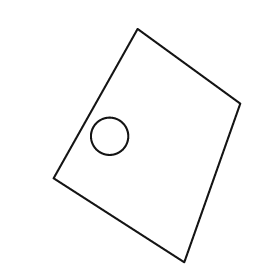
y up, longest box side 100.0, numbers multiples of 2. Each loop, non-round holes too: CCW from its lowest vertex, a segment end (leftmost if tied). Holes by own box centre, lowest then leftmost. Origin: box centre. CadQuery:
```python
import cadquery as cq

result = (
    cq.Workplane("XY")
    .moveTo(16.0, -50.0)
    .lineTo(40.0, 18.0)
    .lineTo(-4.0, 50.0)
    .lineTo(-40.0, -14.0)
    .close()
    .moveTo(-16.0, 4.0)
    .circle(8.0)
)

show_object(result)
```